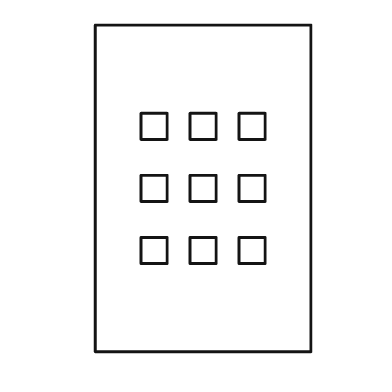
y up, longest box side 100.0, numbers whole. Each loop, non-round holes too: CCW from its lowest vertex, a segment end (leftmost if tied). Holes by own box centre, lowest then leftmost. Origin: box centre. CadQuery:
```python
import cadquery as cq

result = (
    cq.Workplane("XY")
    .moveTo(-33.0, -50.0)
    .lineTo(33.0, -50.0)
    .lineTo(33.0, 50.0)
    .lineTo(-33.0, 50.0)
    .close()
    .moveTo(-19.0, -23.0)
    .lineTo(-11.0, -23.0)
    .lineTo(-11.0, -15.0)
    .lineTo(-19.0, -15.0)
    .close()
    .moveTo(-4.0, -23.0)
    .lineTo(4.0, -23.0)
    .lineTo(4.0, -15.0)
    .lineTo(-4.0, -15.0)
    .close()
    .moveTo(11.0, -23.0)
    .lineTo(19.0, -23.0)
    .lineTo(19.0, -15.0)
    .lineTo(11.0, -15.0)
    .close()
    .moveTo(-19.0, -4.0)
    .lineTo(-11.0, -4.0)
    .lineTo(-11.0, 4.0)
    .lineTo(-19.0, 4.0)
    .close()
    .moveTo(-4.0, -4.0)
    .lineTo(4.0, -4.0)
    .lineTo(4.0, 4.0)
    .lineTo(-4.0, 4.0)
    .close()
    .moveTo(11.0, -4.0)
    .lineTo(19.0, -4.0)
    .lineTo(19.0, 4.0)
    .lineTo(11.0, 4.0)
    .close()
    .moveTo(-19.0, 15.0)
    .lineTo(-11.0, 15.0)
    .lineTo(-11.0, 23.0)
    .lineTo(-19.0, 23.0)
    .close()
    .moveTo(-4.0, 15.0)
    .lineTo(4.0, 15.0)
    .lineTo(4.0, 23.0)
    .lineTo(-4.0, 23.0)
    .close()
    .moveTo(11.0, 15.0)
    .lineTo(19.0, 15.0)
    .lineTo(19.0, 23.0)
    .lineTo(11.0, 23.0)
    .close()
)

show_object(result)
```